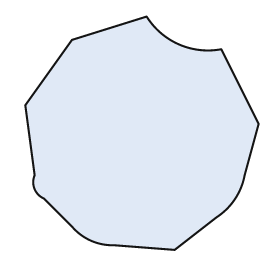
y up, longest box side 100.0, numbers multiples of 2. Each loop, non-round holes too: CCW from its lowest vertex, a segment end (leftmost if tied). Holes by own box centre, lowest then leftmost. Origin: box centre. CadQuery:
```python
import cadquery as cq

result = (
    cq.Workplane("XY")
    .moveTo(14.0, -50.0)
    .lineTo(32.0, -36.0)
    .threePointArc((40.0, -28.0), (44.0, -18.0))
    .lineTo(50.0, 4.0)
    .lineTo(34.0, 36.0)
    .threePointArc((16.0, 38.0), (2.0, 50.0))
    .lineTo(-30.0, 40.0)
    .lineTo(-50.0, 12.0)
    .lineTo(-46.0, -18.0)
    .threePointArc((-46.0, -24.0), (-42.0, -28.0))
    .lineTo(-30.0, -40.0)
    .threePointArc((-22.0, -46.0), (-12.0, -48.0))
    .close()
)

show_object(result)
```